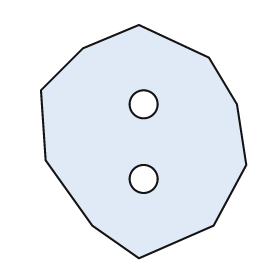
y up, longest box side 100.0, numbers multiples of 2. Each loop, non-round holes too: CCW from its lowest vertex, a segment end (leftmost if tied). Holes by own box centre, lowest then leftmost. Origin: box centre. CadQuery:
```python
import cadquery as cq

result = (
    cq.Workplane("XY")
    .moveTo(-2.0, -50.0)
    .lineTo(30.0, -36.0)
    .lineTo(44.0, -10.0)
    .lineTo(40.0, 16.0)
    .lineTo(28.0, 36.0)
    .lineTo(-2.0, 50.0)
    .lineTo(-26.0, 40.0)
    .lineTo(-44.0, 22.0)
    .lineTo(-42.0, -8.0)
    .lineTo(-22.0, -36.0)
    .close()
    .moveTo(0.0, -16.0)
    .circle(6.0)
    .moveTo(0.0, 16.0)
    .circle(6.0)
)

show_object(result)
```